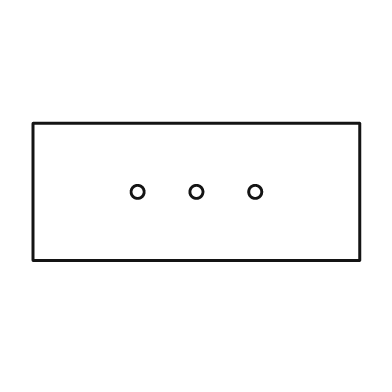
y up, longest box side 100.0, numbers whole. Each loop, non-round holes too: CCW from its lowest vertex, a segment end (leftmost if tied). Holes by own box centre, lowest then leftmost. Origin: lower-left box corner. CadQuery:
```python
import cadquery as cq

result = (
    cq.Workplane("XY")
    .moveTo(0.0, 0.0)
    .lineTo(100.0, 0.0)
    .lineTo(100.0, 42.0)
    .lineTo(0.0, 42.0)
    .close()
    .moveTo(32.0, 21.0)
    .circle(2.0)
    .moveTo(50.0, 21.0)
    .circle(2.0)
    .moveTo(68.0, 21.0)
    .circle(2.0)
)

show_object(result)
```